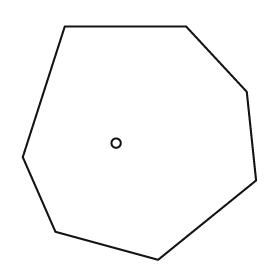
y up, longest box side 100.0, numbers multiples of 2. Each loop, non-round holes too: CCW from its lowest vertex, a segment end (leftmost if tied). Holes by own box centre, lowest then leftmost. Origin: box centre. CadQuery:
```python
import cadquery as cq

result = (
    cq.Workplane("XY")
    .moveTo(8.0, -50.0)
    .lineTo(50.0, -16.0)
    .lineTo(46.0, 22.0)
    .lineTo(20.0, 50.0)
    .lineTo(-32.0, 50.0)
    .lineTo(-50.0, -6.0)
    .lineTo(-36.0, -38.0)
    .close()
    .moveTo(-10.0, 0.0)
    .circle(2.0)
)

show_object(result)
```